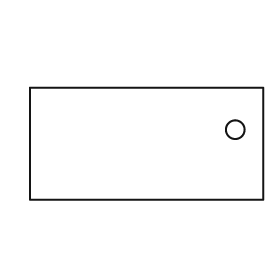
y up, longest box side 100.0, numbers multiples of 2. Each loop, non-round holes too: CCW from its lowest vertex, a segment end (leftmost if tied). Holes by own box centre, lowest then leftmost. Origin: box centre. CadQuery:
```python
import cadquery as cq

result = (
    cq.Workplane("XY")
    .moveTo(-50.0, -24.0)
    .lineTo(50.0, -24.0)
    .lineTo(50.0, 24.0)
    .lineTo(-50.0, 24.0)
    .close()
    .moveTo(38.0, 6.0)
    .circle(4.0)
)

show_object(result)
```